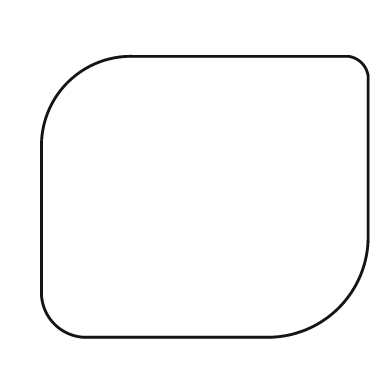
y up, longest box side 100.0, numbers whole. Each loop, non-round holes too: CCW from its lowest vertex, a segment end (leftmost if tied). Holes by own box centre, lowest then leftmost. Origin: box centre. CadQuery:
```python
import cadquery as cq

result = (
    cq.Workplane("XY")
    .moveTo(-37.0, -43.0)
    .lineTo(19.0, -43.0)
    .threePointArc((41.0, -34.0), (50.0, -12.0))
    .lineTo(50.0, 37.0)
    .threePointArc((48.0, 41.0), (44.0, 43.0))
    .lineTo(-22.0, 43.0)
    .threePointArc((-42.0, 35.0), (-50.0, 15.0))
    .lineTo(-50.0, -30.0)
    .threePointArc((-46.0, -39.0), (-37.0, -43.0))
    .close()
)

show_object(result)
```